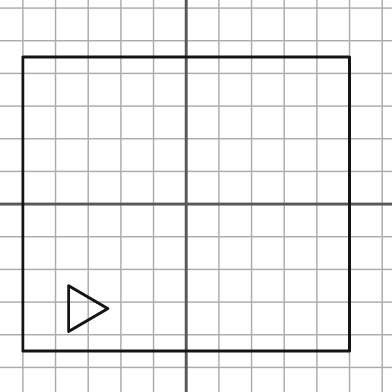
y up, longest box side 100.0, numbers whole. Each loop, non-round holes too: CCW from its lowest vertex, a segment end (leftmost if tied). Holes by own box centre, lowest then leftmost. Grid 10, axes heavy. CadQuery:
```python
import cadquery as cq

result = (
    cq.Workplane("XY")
    .moveTo(-50.0, -45.0)
    .lineTo(50.0, -45.0)
    .lineTo(50.0, 45.0)
    .lineTo(-50.0, 45.0)
    .close()
    .moveTo(-36.0, -39.0)
    .lineTo(-24.0, -32.0)
    .lineTo(-36.0, -25.0)
    .close()
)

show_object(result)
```